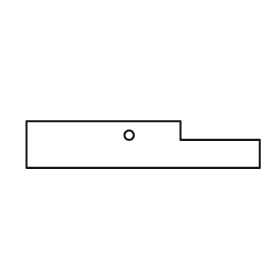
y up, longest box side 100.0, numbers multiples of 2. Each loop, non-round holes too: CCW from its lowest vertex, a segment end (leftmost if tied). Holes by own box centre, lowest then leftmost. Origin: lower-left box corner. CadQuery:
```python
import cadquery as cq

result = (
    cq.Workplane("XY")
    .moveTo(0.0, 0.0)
    .lineTo(100.0, 0.0)
    .lineTo(100.0, 12.0)
    .lineTo(66.0, 12.0)
    .lineTo(66.0, 20.0)
    .lineTo(0.0, 20.0)
    .close()
    .moveTo(44.0, 14.0)
    .circle(2.0)
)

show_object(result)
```